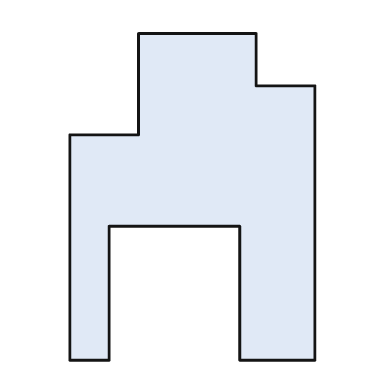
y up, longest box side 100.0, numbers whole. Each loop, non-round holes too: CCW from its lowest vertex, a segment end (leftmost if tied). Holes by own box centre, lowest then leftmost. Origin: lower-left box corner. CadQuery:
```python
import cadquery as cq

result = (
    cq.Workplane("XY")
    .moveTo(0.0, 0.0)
    .lineTo(12.0, 0.0)
    .lineTo(12.0, 41.0)
    .lineTo(52.0, 41.0)
    .lineTo(52.0, 0.0)
    .lineTo(75.0, 0.0)
    .lineTo(75.0, 84.0)
    .lineTo(57.0, 84.0)
    .lineTo(57.0, 100.0)
    .lineTo(21.0, 100.0)
    .lineTo(21.0, 69.0)
    .lineTo(0.0, 69.0)
    .close()
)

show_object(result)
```